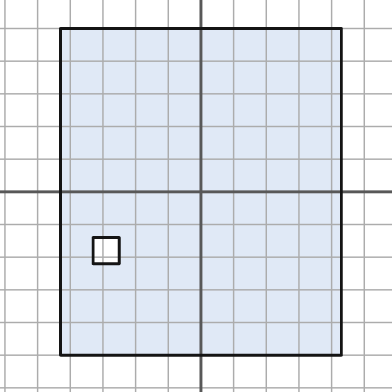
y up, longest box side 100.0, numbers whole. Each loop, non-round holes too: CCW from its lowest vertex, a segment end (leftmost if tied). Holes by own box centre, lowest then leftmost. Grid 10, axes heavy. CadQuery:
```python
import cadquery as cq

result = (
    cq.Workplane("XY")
    .moveTo(-43.0, -50.0)
    .lineTo(43.0, -50.0)
    .lineTo(43.0, 50.0)
    .lineTo(-43.0, 50.0)
    .close()
    .moveTo(-33.0, -22.0)
    .lineTo(-25.0, -22.0)
    .lineTo(-25.0, -14.0)
    .lineTo(-33.0, -14.0)
    .close()
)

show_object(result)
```